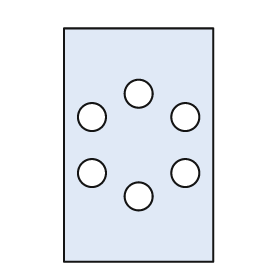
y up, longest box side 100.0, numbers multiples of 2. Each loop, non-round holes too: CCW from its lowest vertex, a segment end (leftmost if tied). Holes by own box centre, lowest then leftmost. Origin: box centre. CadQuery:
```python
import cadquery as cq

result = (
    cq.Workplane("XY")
    .moveTo(-32.0, -50.0)
    .lineTo(32.0, -50.0)
    .lineTo(32.0, 50.0)
    .lineTo(-32.0, 50.0)
    .close()
    .moveTo(0.0, -22.0)
    .circle(6.0)
    .moveTo(-20.0, -12.0)
    .circle(6.0)
    .moveTo(20.0, -12.0)
    .circle(6.0)
    .moveTo(-20.0, 12.0)
    .circle(6.0)
    .moveTo(20.0, 12.0)
    .circle(6.0)
    .moveTo(0.0, 22.0)
    .circle(6.0)
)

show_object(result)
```